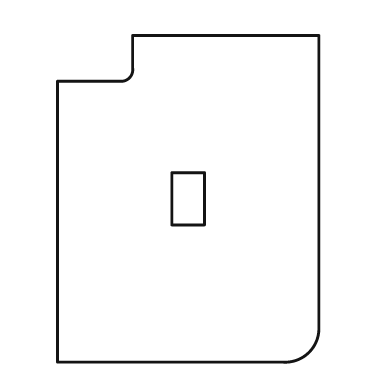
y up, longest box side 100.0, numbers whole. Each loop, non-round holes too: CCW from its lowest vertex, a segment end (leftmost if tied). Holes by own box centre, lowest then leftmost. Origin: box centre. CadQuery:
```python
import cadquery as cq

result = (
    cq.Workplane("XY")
    .moveTo(-40.0, -50.0)
    .lineTo(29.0, -50.0)
    .threePointArc((37.0, -47.0), (40.0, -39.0))
    .lineTo(40.0, 50.0)
    .lineTo(-17.0, 50.0)
    .lineTo(-17.0, 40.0)
    .threePointArc((-18.0, 37.0), (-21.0, 36.0))
    .lineTo(-40.0, 36.0)
    .close()
    .moveTo(-5.0, -8.0)
    .lineTo(5.0, -8.0)
    .lineTo(5.0, 8.0)
    .lineTo(-5.0, 8.0)
    .close()
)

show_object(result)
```